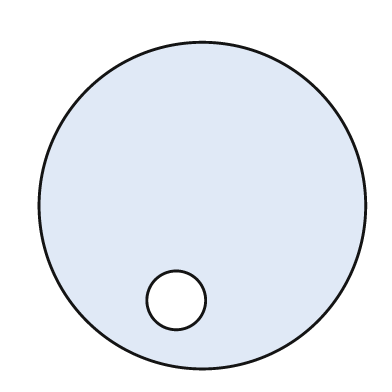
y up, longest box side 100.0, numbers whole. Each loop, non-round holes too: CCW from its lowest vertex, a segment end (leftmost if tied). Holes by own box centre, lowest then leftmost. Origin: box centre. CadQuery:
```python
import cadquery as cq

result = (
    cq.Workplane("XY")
    .moveTo(0.0, 0.0)
    .circle(50.0)
    .moveTo(-8.0, -29.0)
    .circle(9.0)
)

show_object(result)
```